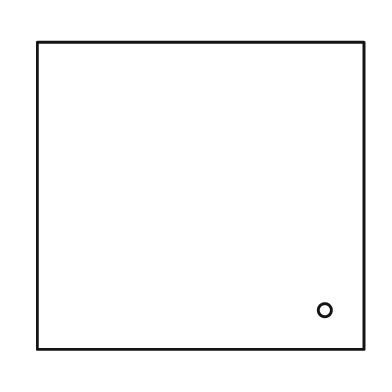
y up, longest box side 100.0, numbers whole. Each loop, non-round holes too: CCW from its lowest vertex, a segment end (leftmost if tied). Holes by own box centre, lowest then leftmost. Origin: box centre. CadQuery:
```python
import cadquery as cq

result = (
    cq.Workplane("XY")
    .moveTo(-50.0, -47.0)
    .lineTo(50.0, -47.0)
    .lineTo(50.0, 47.0)
    .lineTo(-50.0, 47.0)
    .close()
    .moveTo(38.0, -35.0)
    .circle(2.0)
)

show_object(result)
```